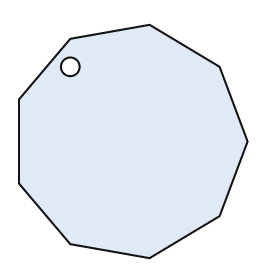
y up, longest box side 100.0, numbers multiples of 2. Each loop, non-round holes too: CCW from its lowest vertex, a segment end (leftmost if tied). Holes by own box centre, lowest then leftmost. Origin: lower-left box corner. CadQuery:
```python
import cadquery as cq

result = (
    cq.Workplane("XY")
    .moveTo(56.0, 0.0)
    .lineTo(86.0, 18.0)
    .lineTo(98.0, 50.0)
    .lineTo(86.0, 82.0)
    .lineTo(56.0, 100.0)
    .lineTo(22.0, 94.0)
    .lineTo(0.0, 68.0)
    .lineTo(0.0, 32.0)
    .lineTo(22.0, 6.0)
    .close()
    .moveTo(22.0, 82.0)
    .circle(4.0)
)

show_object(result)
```